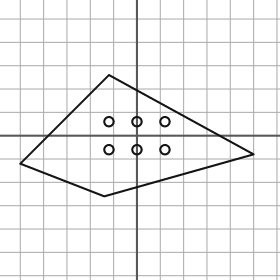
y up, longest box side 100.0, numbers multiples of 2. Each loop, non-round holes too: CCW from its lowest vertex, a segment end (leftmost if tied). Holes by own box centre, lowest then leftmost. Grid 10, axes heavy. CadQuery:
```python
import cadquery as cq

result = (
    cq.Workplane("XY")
    .moveTo(-14.0, -26.0)
    .lineTo(50.0, -8.0)
    .lineTo(-12.0, 26.0)
    .lineTo(-50.0, -12.0)
    .close()
    .moveTo(-12.0, -6.0)
    .circle(2.0)
    .moveTo(0.0, -6.0)
    .circle(2.0)
    .moveTo(12.0, -6.0)
    .circle(2.0)
    .moveTo(-12.0, 6.0)
    .circle(2.0)
    .moveTo(0.0, 6.0)
    .circle(2.0)
    .moveTo(12.0, 6.0)
    .circle(2.0)
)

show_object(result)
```